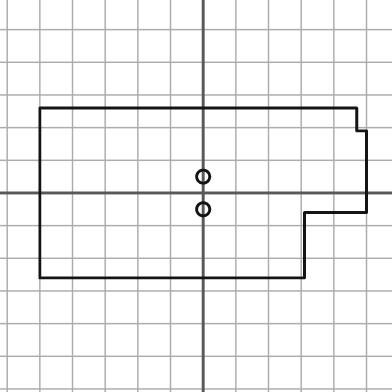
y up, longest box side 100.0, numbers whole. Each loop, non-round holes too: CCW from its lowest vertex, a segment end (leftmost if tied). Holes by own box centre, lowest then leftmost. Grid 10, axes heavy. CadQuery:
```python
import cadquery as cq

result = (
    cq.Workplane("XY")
    .moveTo(-50.0, -26.0)
    .lineTo(31.0, -26.0)
    .lineTo(31.0, -6.0)
    .lineTo(50.0, -6.0)
    .lineTo(50.0, 19.0)
    .lineTo(47.0, 19.0)
    .lineTo(47.0, 26.0)
    .lineTo(-50.0, 26.0)
    .close()
    .moveTo(0.0, -5.0)
    .circle(2.0)
    .moveTo(0.0, 5.0)
    .circle(2.0)
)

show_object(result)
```